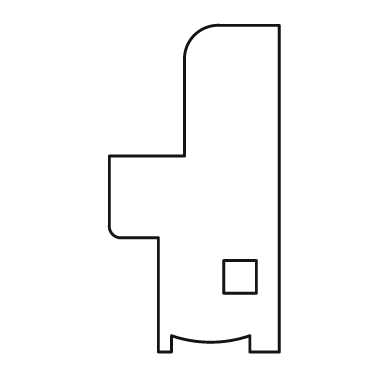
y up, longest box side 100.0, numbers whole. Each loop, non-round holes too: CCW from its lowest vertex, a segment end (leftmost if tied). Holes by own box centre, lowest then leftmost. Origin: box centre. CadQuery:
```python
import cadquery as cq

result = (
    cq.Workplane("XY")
    .moveTo(-11.0, -50.0)
    .lineTo(-7.0, -50.0)
    .lineTo(-7.0, -45.0)
    .threePointArc((5.0, -47.0), (17.0, -45.0))
    .lineTo(17.0, -50.0)
    .lineTo(26.0, -50.0)
    .lineTo(26.0, 50.0)
    .lineTo(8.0, 50.0)
    .threePointArc((0.0, 47.0), (-3.0, 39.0))
    .lineTo(-3.0, 10.0)
    .lineTo(-26.0, 10.0)
    .lineTo(-26.0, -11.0)
    .threePointArc((-25.0, -14.0), (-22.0, -15.0))
    .lineTo(-11.0, -15.0)
    .close()
    .moveTo(9.0, -32.0)
    .lineTo(19.0, -32.0)
    .lineTo(19.0, -22.0)
    .lineTo(9.0, -22.0)
    .close()
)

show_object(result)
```